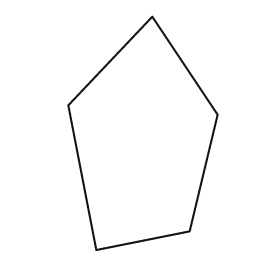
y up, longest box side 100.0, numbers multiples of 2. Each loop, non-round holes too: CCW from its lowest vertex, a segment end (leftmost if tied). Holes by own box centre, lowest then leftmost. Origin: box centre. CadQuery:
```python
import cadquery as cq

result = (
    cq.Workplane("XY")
    .moveTo(-20.0, -50.0)
    .lineTo(20.0, -42.0)
    .lineTo(32.0, 8.0)
    .lineTo(4.0, 50.0)
    .lineTo(-32.0, 12.0)
    .close()
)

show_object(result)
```